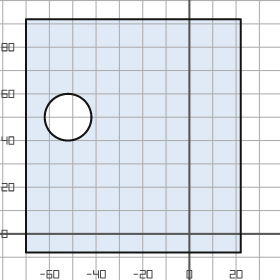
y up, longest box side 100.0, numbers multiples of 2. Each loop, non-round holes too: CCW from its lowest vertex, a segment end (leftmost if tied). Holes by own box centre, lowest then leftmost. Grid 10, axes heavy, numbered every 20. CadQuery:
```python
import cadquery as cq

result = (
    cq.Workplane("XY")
    .moveTo(-70.0, -8.0)
    .lineTo(22.0, -8.0)
    .lineTo(22.0, 92.0)
    .lineTo(-70.0, 92.0)
    .close()
    .moveTo(-52.0, 50.0)
    .circle(10.0)
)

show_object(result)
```